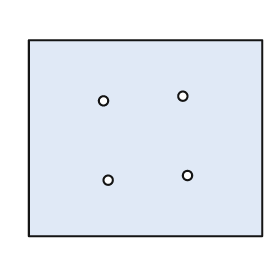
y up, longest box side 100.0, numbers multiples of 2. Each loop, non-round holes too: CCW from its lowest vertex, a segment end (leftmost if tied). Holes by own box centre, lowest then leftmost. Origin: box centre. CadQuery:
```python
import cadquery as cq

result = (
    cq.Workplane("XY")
    .moveTo(-50.0, -42.0)
    .lineTo(50.0, -42.0)
    .lineTo(50.0, 42.0)
    .lineTo(-50.0, 42.0)
    .close()
    .moveTo(-16.0, -18.0)
    .circle(2.0)
    .moveTo(18.0, -16.0)
    .circle(2.0)
    .moveTo(-18.0, 16.0)
    .circle(2.0)
    .moveTo(16.0, 18.0)
    .circle(2.0)
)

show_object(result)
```